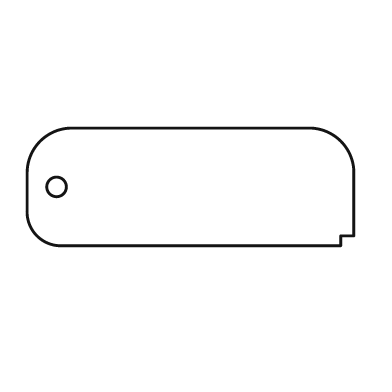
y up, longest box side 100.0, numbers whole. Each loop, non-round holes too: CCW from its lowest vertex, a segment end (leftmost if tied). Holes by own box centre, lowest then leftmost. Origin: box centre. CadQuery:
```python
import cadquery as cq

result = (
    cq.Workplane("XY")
    .moveTo(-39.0, -18.0)
    .lineTo(46.0, -18.0)
    .lineTo(46.0, -15.0)
    .lineTo(50.0, -15.0)
    .lineTo(50.0, 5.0)
    .threePointArc((46.0, 14.0), (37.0, 18.0))
    .lineTo(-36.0, 18.0)
    .threePointArc((-46.0, 14.0), (-50.0, 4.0))
    .lineTo(-50.0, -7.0)
    .threePointArc((-47.0, -15.0), (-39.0, -18.0))
    .close()
    .moveTo(-41.0, 0.0)
    .circle(3.0)
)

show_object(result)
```